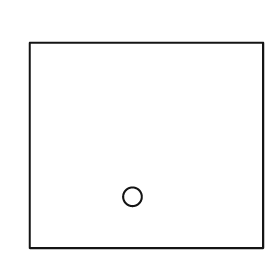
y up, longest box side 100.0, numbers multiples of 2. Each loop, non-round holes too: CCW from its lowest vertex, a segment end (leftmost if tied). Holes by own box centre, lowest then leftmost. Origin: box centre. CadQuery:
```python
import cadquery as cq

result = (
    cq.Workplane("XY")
    .moveTo(-50.0, -44.0)
    .lineTo(50.0, -44.0)
    .lineTo(50.0, 44.0)
    .lineTo(-50.0, 44.0)
    .close()
    .moveTo(-6.0, -22.0)
    .circle(4.0)
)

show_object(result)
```